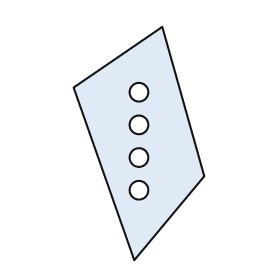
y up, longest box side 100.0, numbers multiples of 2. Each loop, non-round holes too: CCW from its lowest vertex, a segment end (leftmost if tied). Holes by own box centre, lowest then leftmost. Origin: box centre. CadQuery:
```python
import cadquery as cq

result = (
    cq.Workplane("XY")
    .moveTo(-2.0, -50.0)
    .lineTo(28.0, -14.0)
    .lineTo(10.0, 50.0)
    .lineTo(-28.0, 24.0)
    .close()
    .moveTo(0.0, -20.0)
    .circle(4.0)
    .moveTo(0.0, -6.0)
    .circle(4.0)
    .moveTo(0.0, 8.0)
    .circle(4.0)
    .moveTo(0.0, 22.0)
    .circle(4.0)
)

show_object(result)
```